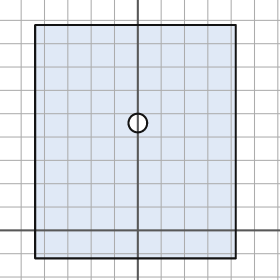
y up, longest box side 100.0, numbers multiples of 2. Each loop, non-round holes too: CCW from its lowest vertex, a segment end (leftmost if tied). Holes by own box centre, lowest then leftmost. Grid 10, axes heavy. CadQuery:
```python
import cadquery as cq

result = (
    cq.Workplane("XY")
    .moveTo(-44.0, -12.0)
    .lineTo(42.0, -12.0)
    .lineTo(42.0, 88.0)
    .lineTo(-44.0, 88.0)
    .close()
    .moveTo(0.0, 46.0)
    .circle(4.0)
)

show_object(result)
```